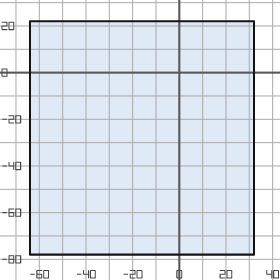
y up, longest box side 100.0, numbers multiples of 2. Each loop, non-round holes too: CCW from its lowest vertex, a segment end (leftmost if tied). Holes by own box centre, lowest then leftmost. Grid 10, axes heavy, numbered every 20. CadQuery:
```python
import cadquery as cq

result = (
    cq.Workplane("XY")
    .moveTo(-64.0, -78.0)
    .lineTo(32.0, -78.0)
    .lineTo(32.0, 22.0)
    .lineTo(-64.0, 22.0)
    .close()
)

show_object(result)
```